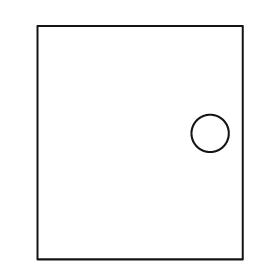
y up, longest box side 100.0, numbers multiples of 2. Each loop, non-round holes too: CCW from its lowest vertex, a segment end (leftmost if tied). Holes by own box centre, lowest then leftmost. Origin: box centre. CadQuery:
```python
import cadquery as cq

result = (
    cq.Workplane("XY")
    .moveTo(-44.0, -50.0)
    .lineTo(44.0, -50.0)
    .lineTo(44.0, 50.0)
    .lineTo(-44.0, 50.0)
    .close()
    .moveTo(30.0, 4.0)
    .circle(8.0)
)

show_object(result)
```